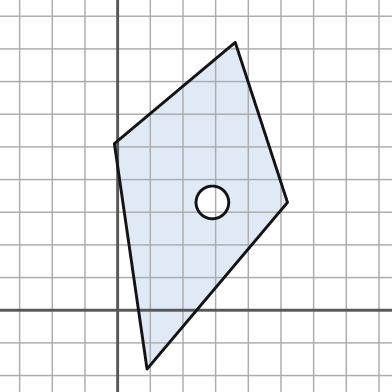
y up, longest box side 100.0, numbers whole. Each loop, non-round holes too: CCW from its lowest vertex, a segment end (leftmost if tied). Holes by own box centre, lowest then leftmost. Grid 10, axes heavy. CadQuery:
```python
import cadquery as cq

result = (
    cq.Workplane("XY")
    .moveTo(9.0, -18.0)
    .lineTo(52.0, 33.0)
    .lineTo(36.0, 82.0)
    .lineTo(-1.0, 51.0)
    .close()
    .moveTo(29.0, 33.0)
    .circle(5.0)
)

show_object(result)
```